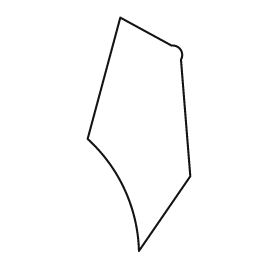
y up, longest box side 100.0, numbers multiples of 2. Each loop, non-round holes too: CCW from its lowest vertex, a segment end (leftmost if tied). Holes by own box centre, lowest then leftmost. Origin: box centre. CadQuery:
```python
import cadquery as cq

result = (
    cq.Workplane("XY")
    .moveTo(0.0, -50.0)
    .lineTo(22.0, -18.0)
    .lineTo(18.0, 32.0)
    .threePointArc((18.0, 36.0), (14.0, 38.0))
    .lineTo(-8.0, 50.0)
    .lineTo(-22.0, -2.0)
    .threePointArc((-6.0, -24.0), (0.0, -50.0))
    .close()
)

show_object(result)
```